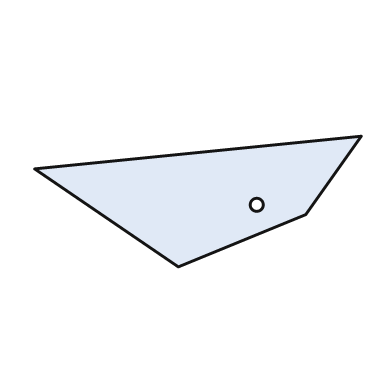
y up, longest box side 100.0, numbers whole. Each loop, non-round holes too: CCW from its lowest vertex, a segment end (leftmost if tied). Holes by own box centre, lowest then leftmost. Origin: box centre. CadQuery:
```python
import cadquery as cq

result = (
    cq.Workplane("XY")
    .moveTo(-6.0, -20.0)
    .lineTo(33.0, -4.0)
    .lineTo(50.0, 20.0)
    .lineTo(-50.0, 10.0)
    .close()
    .moveTo(18.0, -1.0)
    .circle(2.0)
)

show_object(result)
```